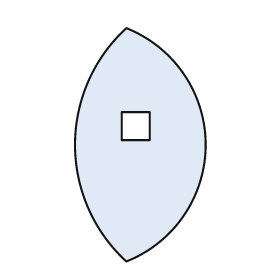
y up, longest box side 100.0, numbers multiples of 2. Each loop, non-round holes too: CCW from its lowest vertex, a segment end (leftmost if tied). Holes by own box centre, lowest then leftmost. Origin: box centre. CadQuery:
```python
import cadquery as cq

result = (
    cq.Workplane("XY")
    .moveTo(-6.0, -50.0)
    .threePointArc((28.0, 0.0), (-6.0, 50.0))
    .threePointArc((-28.0, 0.0), (-6.0, -50.0))
    .close()
    .moveTo(-8.0, 2.0)
    .lineTo(4.0, 2.0)
    .lineTo(4.0, 14.0)
    .lineTo(-8.0, 14.0)
    .close()
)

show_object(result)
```